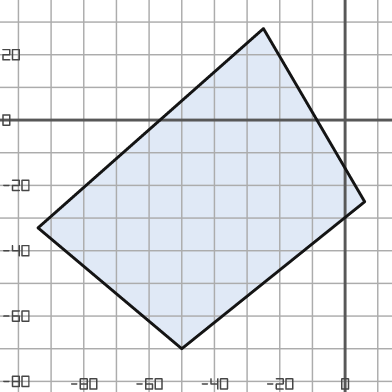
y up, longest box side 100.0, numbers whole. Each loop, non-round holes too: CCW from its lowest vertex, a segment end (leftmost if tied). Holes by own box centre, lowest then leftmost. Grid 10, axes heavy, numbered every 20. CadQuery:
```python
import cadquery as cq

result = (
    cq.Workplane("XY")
    .moveTo(-50.0, -70.0)
    .lineTo(6.0, -25.0)
    .lineTo(-25.0, 28.0)
    .lineTo(-94.0, -33.0)
    .close()
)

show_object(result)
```